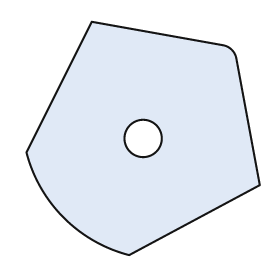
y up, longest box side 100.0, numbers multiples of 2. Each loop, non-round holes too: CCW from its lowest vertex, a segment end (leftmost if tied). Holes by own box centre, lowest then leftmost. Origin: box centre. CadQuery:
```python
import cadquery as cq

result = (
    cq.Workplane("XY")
    .moveTo(-6.0, -50.0)
    .lineTo(50.0, -20.0)
    .lineTo(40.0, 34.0)
    .threePointArc((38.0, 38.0), (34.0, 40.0))
    .lineTo(-22.0, 50.0)
    .lineTo(-50.0, -6.0)
    .threePointArc((-34.0, -34.0), (-6.0, -50.0))
    .close()
    .moveTo(0.0, 0.0)
    .circle(8.0)
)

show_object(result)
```